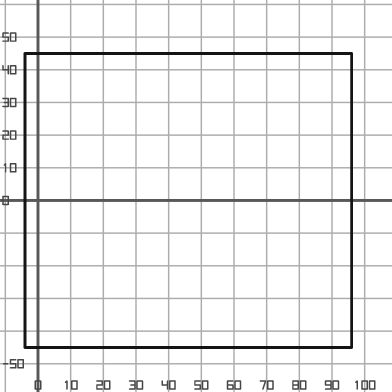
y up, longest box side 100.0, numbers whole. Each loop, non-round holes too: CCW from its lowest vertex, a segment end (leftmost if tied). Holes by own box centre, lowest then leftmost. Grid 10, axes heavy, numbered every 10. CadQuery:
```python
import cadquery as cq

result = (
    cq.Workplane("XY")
    .moveTo(-4.0, -45.0)
    .lineTo(96.0, -45.0)
    .lineTo(96.0, 45.0)
    .lineTo(-4.0, 45.0)
    .close()
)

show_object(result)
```